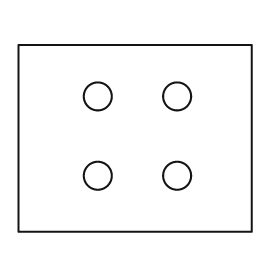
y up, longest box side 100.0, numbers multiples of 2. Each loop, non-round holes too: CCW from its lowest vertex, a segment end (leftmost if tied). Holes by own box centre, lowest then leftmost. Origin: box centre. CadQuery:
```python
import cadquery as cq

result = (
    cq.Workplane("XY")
    .moveTo(-50.0, -40.0)
    .lineTo(50.0, -40.0)
    .lineTo(50.0, 40.0)
    .lineTo(-50.0, 40.0)
    .close()
    .moveTo(-16.0, -16.0)
    .circle(6.0)
    .moveTo(18.0, -16.0)
    .circle(6.0)
    .moveTo(-16.0, 18.0)
    .circle(6.0)
    .moveTo(18.0, 18.0)
    .circle(6.0)
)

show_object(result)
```